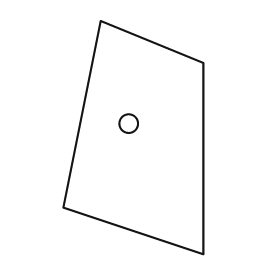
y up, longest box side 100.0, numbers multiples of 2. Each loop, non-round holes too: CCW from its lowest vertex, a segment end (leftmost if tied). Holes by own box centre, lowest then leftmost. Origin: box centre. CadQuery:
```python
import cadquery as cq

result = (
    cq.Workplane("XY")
    .moveTo(30.0, -50.0)
    .lineTo(30.0, 32.0)
    .lineTo(-14.0, 50.0)
    .lineTo(-30.0, -30.0)
    .close()
    .moveTo(-2.0, 6.0)
    .circle(4.0)
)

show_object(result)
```